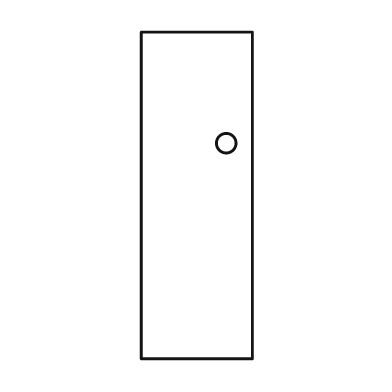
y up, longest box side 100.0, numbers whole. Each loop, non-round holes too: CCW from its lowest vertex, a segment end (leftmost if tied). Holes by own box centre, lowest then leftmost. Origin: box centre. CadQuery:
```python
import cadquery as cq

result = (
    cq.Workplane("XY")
    .moveTo(-17.0, -50.0)
    .lineTo(17.0, -50.0)
    .lineTo(17.0, 50.0)
    .lineTo(-17.0, 50.0)
    .close()
    .moveTo(9.0, 16.0)
    .circle(3.0)
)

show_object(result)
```